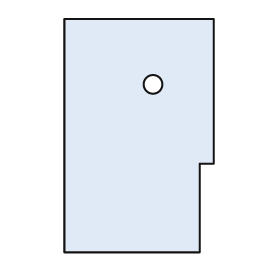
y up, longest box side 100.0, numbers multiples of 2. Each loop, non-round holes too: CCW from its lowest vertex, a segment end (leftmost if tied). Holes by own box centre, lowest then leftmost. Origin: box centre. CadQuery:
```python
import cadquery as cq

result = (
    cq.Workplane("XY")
    .moveTo(-32.0, -50.0)
    .lineTo(26.0, -50.0)
    .lineTo(26.0, -12.0)
    .lineTo(32.0, -12.0)
    .lineTo(32.0, 50.0)
    .lineTo(-32.0, 50.0)
    .close()
    .moveTo(6.0, 22.0)
    .circle(4.0)
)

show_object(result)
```